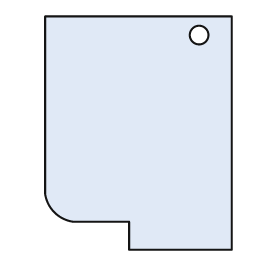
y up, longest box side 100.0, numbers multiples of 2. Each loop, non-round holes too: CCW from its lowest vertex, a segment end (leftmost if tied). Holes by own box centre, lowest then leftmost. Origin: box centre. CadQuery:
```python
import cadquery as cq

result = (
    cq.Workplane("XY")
    .moveTo(-4.0, -50.0)
    .lineTo(40.0, -50.0)
    .lineTo(40.0, 50.0)
    .lineTo(-40.0, 50.0)
    .lineTo(-40.0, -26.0)
    .threePointArc((-36.0, -34.0), (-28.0, -38.0))
    .lineTo(-4.0, -38.0)
    .close()
    .moveTo(26.0, 42.0)
    .circle(4.0)
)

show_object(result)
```